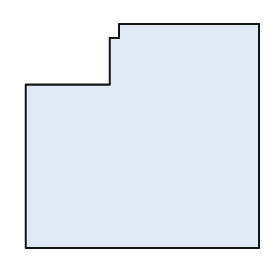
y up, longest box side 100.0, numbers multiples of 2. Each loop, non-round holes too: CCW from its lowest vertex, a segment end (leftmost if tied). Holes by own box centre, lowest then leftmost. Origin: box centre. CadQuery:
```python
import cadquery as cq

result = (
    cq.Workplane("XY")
    .moveTo(-50.0, -48.0)
    .lineTo(50.0, -48.0)
    .lineTo(50.0, 48.0)
    .lineTo(-10.0, 48.0)
    .lineTo(-10.0, 42.0)
    .lineTo(-14.0, 42.0)
    .lineTo(-14.0, 22.0)
    .lineTo(-50.0, 22.0)
    .close()
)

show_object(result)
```